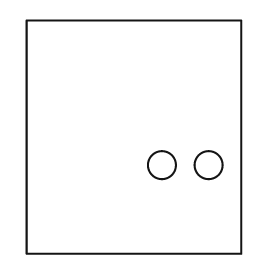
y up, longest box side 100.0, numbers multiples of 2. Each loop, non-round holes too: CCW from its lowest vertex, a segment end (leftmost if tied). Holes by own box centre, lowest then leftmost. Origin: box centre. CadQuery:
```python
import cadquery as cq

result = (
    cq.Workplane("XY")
    .moveTo(-46.0, -50.0)
    .lineTo(46.0, -50.0)
    .lineTo(46.0, 50.0)
    .lineTo(-46.0, 50.0)
    .close()
    .moveTo(12.0, -12.0)
    .circle(6.0)
    .moveTo(32.0, -12.0)
    .circle(6.0)
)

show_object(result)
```